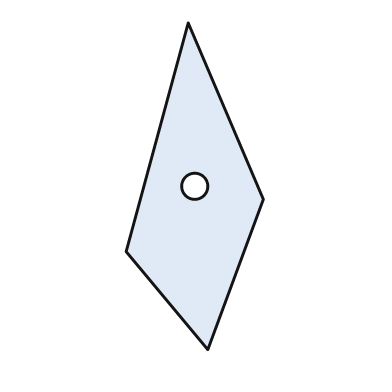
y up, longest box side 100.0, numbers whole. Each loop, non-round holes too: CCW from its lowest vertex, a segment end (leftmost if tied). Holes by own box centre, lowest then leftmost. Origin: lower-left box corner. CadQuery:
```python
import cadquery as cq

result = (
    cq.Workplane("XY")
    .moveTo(25.0, 0.0)
    .lineTo(42.0, 46.0)
    .lineTo(19.0, 100.0)
    .lineTo(0.0, 30.0)
    .close()
    .moveTo(21.0, 50.0)
    .circle(4.0)
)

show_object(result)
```